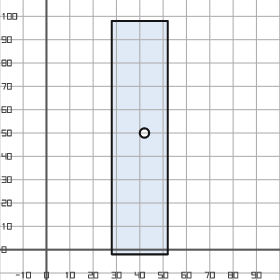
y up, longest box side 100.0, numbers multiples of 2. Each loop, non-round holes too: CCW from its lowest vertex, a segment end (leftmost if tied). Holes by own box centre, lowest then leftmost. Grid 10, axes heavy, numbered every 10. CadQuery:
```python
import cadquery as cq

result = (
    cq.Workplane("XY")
    .moveTo(28.0, -2.0)
    .lineTo(52.0, -2.0)
    .lineTo(52.0, 98.0)
    .lineTo(28.0, 98.0)
    .close()
    .moveTo(42.0, 50.0)
    .circle(2.0)
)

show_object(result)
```